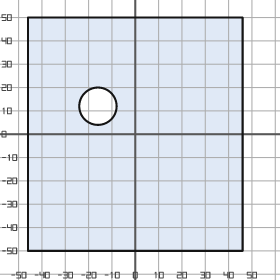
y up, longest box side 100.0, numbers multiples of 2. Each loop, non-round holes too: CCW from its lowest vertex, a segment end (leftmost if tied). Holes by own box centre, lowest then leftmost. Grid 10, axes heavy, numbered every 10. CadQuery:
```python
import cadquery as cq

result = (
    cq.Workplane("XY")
    .moveTo(-46.0, -50.0)
    .lineTo(46.0, -50.0)
    .lineTo(46.0, 50.0)
    .lineTo(-46.0, 50.0)
    .close()
    .moveTo(-16.0, 12.0)
    .circle(8.0)
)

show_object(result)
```